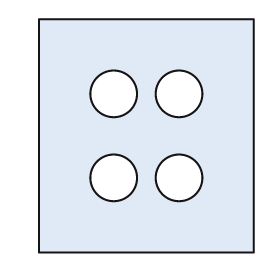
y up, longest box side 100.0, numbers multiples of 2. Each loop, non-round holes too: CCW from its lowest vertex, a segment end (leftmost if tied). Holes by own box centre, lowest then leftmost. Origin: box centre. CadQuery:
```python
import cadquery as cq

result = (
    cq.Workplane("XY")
    .moveTo(-46.0, -50.0)
    .lineTo(46.0, -50.0)
    .lineTo(46.0, 50.0)
    .lineTo(-46.0, 50.0)
    .close()
    .moveTo(-14.0, -18.0)
    .circle(10.0)
    .moveTo(14.0, -18.0)
    .circle(10.0)
    .moveTo(-14.0, 18.0)
    .circle(10.0)
    .moveTo(14.0, 18.0)
    .circle(10.0)
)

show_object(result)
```